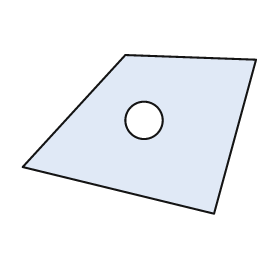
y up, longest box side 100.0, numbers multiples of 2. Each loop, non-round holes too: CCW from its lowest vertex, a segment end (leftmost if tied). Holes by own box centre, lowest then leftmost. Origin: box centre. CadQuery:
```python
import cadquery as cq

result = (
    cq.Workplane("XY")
    .moveTo(32.0, -34.0)
    .lineTo(50.0, 32.0)
    .lineTo(-6.0, 34.0)
    .lineTo(-50.0, -14.0)
    .close()
    .moveTo(2.0, 6.0)
    .circle(8.0)
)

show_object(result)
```